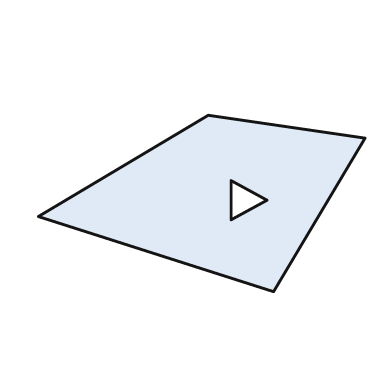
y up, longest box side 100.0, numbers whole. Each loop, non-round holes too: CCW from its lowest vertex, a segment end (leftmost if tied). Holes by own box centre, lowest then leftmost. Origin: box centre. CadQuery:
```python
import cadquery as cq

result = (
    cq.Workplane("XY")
    .moveTo(22.0, -27.0)
    .lineTo(50.0, 20.0)
    .lineTo(2.0, 27.0)
    .lineTo(-50.0, -4.0)
    .close()
    .moveTo(9.0, -5.0)
    .lineTo(20.0, 1.0)
    .lineTo(9.0, 7.0)
    .close()
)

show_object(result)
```